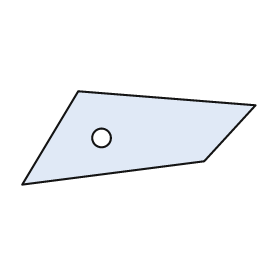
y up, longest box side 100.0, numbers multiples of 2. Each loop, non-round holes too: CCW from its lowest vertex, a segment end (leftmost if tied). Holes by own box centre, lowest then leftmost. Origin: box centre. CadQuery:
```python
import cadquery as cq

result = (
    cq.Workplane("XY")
    .moveTo(-50.0, -20.0)
    .lineTo(28.0, -10.0)
    .lineTo(50.0, 14.0)
    .lineTo(-26.0, 20.0)
    .close()
    .moveTo(-16.0, 0.0)
    .circle(4.0)
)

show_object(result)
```